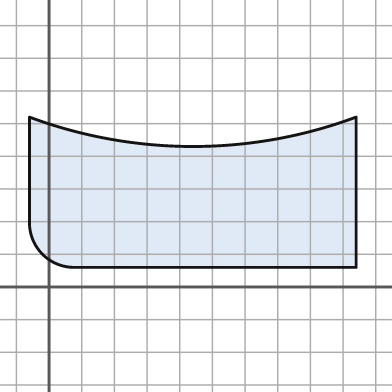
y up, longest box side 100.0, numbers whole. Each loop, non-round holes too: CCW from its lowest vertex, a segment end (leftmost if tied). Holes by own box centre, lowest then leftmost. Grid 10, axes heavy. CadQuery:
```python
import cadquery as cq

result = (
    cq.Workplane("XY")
    .moveTo(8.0, 6.0)
    .lineTo(94.0, 6.0)
    .lineTo(94.0, 52.0)
    .threePointArc((44.0, 43.0), (-6.0, 52.0))
    .lineTo(-6.0, 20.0)
    .threePointArc((-2.0, 10.0), (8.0, 6.0))
    .close()
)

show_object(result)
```